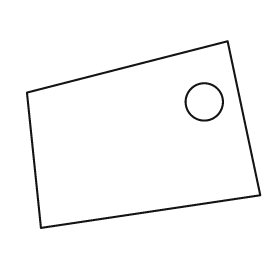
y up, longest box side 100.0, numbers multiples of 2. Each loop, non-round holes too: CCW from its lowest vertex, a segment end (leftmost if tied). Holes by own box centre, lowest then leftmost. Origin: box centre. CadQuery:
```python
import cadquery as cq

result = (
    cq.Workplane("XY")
    .moveTo(-44.0, -40.0)
    .lineTo(50.0, -26.0)
    .lineTo(36.0, 40.0)
    .lineTo(-50.0, 18.0)
    .close()
    .moveTo(26.0, 14.0)
    .circle(8.0)
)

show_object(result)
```